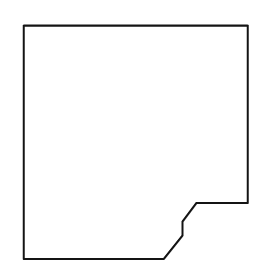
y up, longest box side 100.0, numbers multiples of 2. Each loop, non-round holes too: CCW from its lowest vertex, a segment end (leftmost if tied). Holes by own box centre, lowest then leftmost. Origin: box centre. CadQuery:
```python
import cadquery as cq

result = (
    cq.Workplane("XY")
    .moveTo(-48.0, -50.0)
    .lineTo(12.0, -50.0)
    .lineTo(20.0, -40.0)
    .lineTo(20.0, -34.0)
    .lineTo(26.0, -26.0)
    .lineTo(48.0, -26.0)
    .lineTo(48.0, 50.0)
    .lineTo(-48.0, 50.0)
    .close()
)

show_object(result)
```